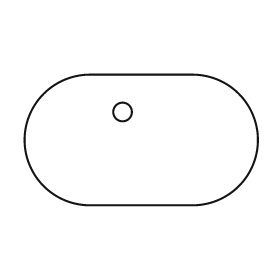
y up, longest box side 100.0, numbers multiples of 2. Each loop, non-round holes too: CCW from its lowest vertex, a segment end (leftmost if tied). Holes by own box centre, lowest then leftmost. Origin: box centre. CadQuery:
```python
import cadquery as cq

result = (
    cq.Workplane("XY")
    .moveTo(-22.0, -28.0)
    .lineTo(22.0, -28.0)
    .threePointArc((50.0, 0.0), (22.0, 28.0))
    .lineTo(-22.0, 28.0)
    .threePointArc((-50.0, 0.0), (-22.0, -28.0))
    .close()
    .moveTo(-8.0, 12.0)
    .circle(4.0)
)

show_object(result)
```